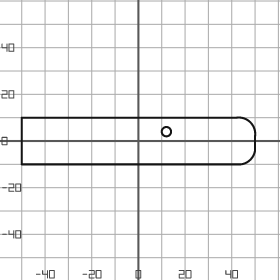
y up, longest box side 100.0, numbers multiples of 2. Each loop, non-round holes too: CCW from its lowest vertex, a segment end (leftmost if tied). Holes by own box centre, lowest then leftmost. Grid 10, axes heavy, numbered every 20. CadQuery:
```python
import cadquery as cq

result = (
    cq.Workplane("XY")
    .moveTo(-50.0, -10.0)
    .lineTo(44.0, -10.0)
    .threePointArc((48.0, -8.0), (50.0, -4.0))
    .lineTo(50.0, 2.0)
    .threePointArc((48.0, 8.0), (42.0, 10.0))
    .lineTo(-50.0, 10.0)
    .close()
    .moveTo(12.0, 4.0)
    .circle(2.0)
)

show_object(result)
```